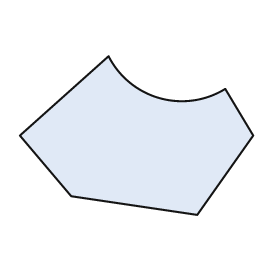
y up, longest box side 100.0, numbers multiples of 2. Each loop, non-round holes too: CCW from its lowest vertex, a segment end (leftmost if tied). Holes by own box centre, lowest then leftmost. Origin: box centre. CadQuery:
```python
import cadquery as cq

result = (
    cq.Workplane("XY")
    .moveTo(26.0, -34.0)
    .lineTo(50.0, 0.0)
    .lineTo(38.0, 20.0)
    .threePointArc((10.0, 16.0), (-12.0, 34.0))
    .lineTo(-50.0, 0.0)
    .lineTo(-28.0, -26.0)
    .close()
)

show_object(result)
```